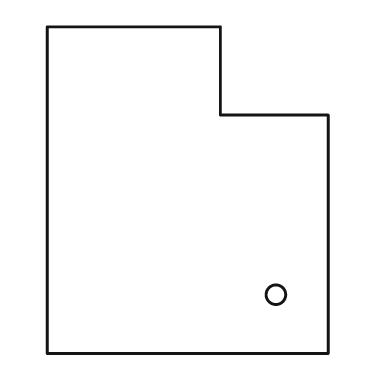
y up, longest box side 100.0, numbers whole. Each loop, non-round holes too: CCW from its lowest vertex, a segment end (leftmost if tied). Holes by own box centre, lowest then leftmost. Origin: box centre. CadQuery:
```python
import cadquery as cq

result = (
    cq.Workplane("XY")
    .moveTo(-43.0, -50.0)
    .lineTo(43.0, -50.0)
    .lineTo(43.0, 23.0)
    .lineTo(10.0, 23.0)
    .lineTo(10.0, 50.0)
    .lineTo(-43.0, 50.0)
    .close()
    .moveTo(27.0, -32.0)
    .circle(3.0)
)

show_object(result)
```